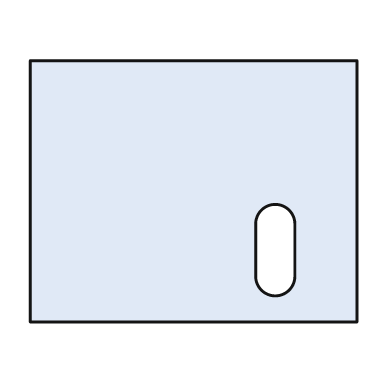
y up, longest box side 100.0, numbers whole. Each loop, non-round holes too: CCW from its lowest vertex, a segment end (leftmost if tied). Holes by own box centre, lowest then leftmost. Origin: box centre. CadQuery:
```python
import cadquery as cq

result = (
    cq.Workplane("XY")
    .moveTo(-50.0, -40.0)
    .lineTo(50.0, -40.0)
    .lineTo(50.0, 40.0)
    .lineTo(-50.0, 40.0)
    .close()
    .moveTo(19.0, -26.0)
    .threePointArc((25.0, -32.0), (31.0, -26.0))
    .lineTo(31.0, -10.0)
    .threePointArc((25.0, -4.0), (19.0, -10.0))
    .close()
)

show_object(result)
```